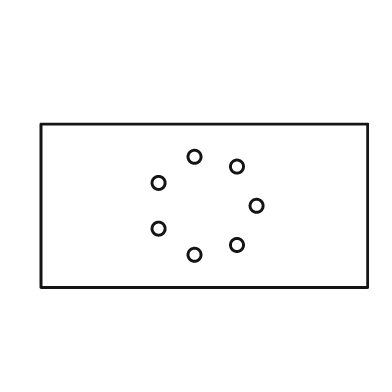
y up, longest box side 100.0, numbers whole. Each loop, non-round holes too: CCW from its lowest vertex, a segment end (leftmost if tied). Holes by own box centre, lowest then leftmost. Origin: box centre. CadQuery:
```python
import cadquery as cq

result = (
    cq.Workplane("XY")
    .moveTo(-50.0, -25.0)
    .lineTo(50.0, -25.0)
    .lineTo(50.0, 25.0)
    .lineTo(-50.0, 25.0)
    .close()
    .moveTo(-3.0, -15.0)
    .circle(2.0)
    .moveTo(10.0, -12.0)
    .circle(2.0)
    .moveTo(-14.0, -7.0)
    .circle(2.0)
    .moveTo(16.0, 0.0)
    .circle(2.0)
    .moveTo(-14.0, 7.0)
    .circle(2.0)
    .moveTo(10.0, 12.0)
    .circle(2.0)
    .moveTo(-3.0, 15.0)
    .circle(2.0)
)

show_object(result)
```